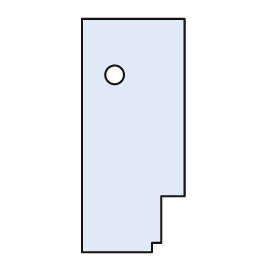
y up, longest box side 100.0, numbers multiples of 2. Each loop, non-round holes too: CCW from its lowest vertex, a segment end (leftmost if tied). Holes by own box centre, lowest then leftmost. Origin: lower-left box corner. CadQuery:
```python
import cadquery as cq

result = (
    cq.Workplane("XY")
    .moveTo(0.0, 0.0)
    .lineTo(30.0, 0.0)
    .lineTo(30.0, 4.0)
    .lineTo(34.0, 4.0)
    .lineTo(34.0, 24.0)
    .lineTo(44.0, 24.0)
    .lineTo(44.0, 100.0)
    .lineTo(0.0, 100.0)
    .close()
    .moveTo(14.0, 76.0)
    .circle(4.0)
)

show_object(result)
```